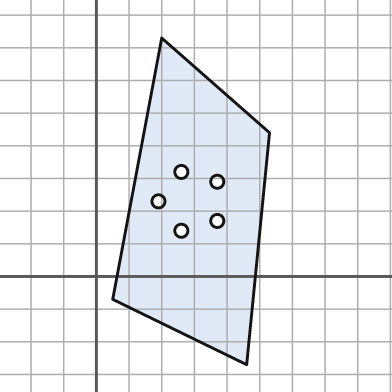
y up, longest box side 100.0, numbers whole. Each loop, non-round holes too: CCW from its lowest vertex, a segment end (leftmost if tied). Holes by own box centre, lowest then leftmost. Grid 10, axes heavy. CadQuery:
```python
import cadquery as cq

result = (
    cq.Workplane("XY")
    .moveTo(46.0, -27.0)
    .lineTo(53.0, 44.0)
    .lineTo(20.0, 73.0)
    .lineTo(5.0, -7.0)
    .close()
    .moveTo(26.0, 14.0)
    .circle(2.0)
    .moveTo(37.0, 17.0)
    .circle(2.0)
    .moveTo(19.0, 23.0)
    .circle(2.0)
    .moveTo(37.0, 29.0)
    .circle(2.0)
    .moveTo(26.0, 32.0)
    .circle(2.0)
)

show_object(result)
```